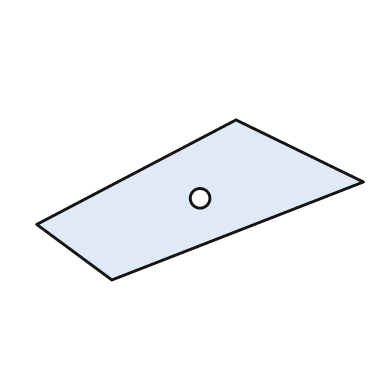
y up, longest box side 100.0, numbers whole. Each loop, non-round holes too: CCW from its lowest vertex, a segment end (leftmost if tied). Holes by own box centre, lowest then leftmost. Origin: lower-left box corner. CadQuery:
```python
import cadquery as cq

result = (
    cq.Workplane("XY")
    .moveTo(23.0, 0.0)
    .lineTo(100.0, 30.0)
    .lineTo(61.0, 49.0)
    .lineTo(0.0, 17.0)
    .close()
    .moveTo(50.0, 25.0)
    .circle(3.0)
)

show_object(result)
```